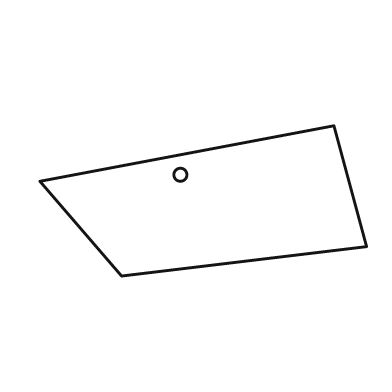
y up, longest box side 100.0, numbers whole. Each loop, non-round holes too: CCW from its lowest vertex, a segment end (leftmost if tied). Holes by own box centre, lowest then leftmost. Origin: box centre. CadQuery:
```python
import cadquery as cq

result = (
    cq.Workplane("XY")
    .moveTo(-25.0, -23.0)
    .lineTo(50.0, -14.0)
    .lineTo(40.0, 23.0)
    .lineTo(-50.0, 6.0)
    .close()
    .moveTo(-7.0, 8.0)
    .circle(2.0)
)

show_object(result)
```